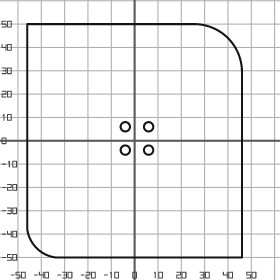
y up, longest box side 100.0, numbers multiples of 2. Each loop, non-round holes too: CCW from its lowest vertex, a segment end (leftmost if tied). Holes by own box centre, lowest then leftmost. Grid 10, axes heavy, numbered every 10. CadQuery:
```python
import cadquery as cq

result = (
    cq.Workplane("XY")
    .moveTo(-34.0, -50.0)
    .lineTo(46.0, -50.0)
    .lineTo(46.0, 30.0)
    .threePointArc((40.0, 44.0), (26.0, 50.0))
    .lineTo(-46.0, 50.0)
    .lineTo(-46.0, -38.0)
    .threePointArc((-42.0, -46.0), (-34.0, -50.0))
    .close()
    .moveTo(-4.0, -4.0)
    .circle(2.0)
    .moveTo(6.0, -4.0)
    .circle(2.0)
    .moveTo(-4.0, 6.0)
    .circle(2.0)
    .moveTo(6.0, 6.0)
    .circle(2.0)
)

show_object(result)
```